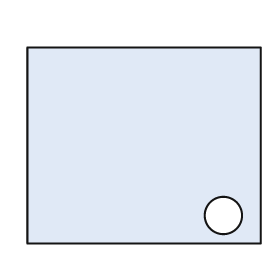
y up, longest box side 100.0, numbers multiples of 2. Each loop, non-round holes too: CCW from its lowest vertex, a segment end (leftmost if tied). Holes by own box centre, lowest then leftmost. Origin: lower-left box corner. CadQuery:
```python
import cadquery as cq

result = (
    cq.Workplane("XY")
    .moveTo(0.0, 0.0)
    .lineTo(100.0, 0.0)
    .lineTo(100.0, 84.0)
    .lineTo(0.0, 84.0)
    .close()
    .moveTo(84.0, 12.0)
    .circle(8.0)
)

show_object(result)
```